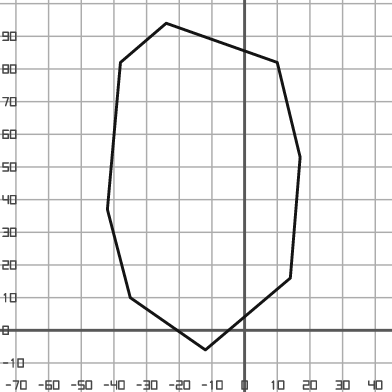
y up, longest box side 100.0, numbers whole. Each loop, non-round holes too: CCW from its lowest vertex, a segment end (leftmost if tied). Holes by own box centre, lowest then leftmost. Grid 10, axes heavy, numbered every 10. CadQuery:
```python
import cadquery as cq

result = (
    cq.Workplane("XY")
    .moveTo(-12.0, -6.0)
    .lineTo(14.0, 16.0)
    .lineTo(17.0, 53.0)
    .lineTo(10.0, 82.0)
    .lineTo(-24.0, 94.0)
    .lineTo(-38.0, 82.0)
    .lineTo(-42.0, 37.0)
    .lineTo(-35.0, 10.0)
    .close()
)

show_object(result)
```